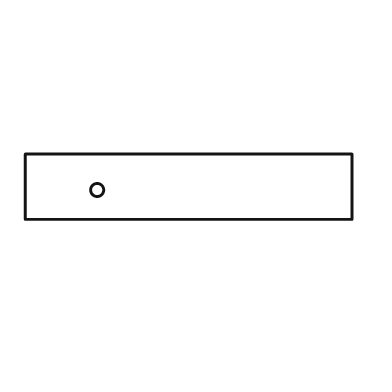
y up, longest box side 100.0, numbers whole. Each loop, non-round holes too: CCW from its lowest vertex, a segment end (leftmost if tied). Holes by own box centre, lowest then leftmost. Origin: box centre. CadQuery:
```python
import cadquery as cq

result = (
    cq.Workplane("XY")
    .moveTo(-50.0, -10.0)
    .lineTo(50.0, -10.0)
    .lineTo(50.0, 10.0)
    .lineTo(-50.0, 10.0)
    .close()
    .moveTo(-28.0, -1.0)
    .circle(2.0)
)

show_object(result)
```